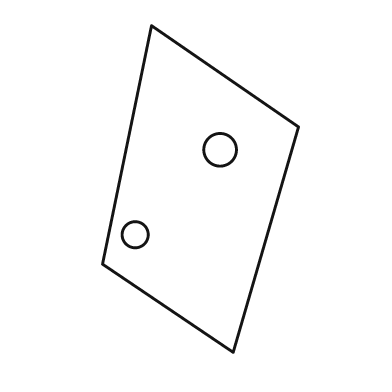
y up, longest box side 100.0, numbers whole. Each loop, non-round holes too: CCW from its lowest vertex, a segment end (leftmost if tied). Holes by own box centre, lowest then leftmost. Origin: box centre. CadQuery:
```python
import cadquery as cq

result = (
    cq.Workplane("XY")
    .moveTo(10.0, -50.0)
    .lineTo(30.0, 19.0)
    .lineTo(-15.0, 50.0)
    .lineTo(-30.0, -23.0)
    .close()
    .moveTo(-20.0, -14.0)
    .circle(4.0)
    .moveTo(6.0, 12.0)
    .circle(5.0)
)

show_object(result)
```